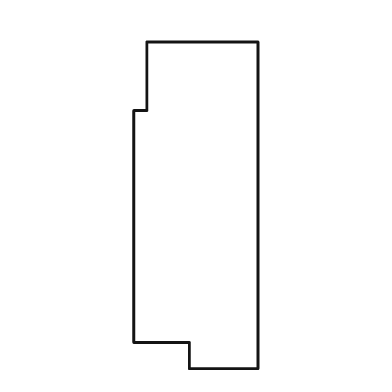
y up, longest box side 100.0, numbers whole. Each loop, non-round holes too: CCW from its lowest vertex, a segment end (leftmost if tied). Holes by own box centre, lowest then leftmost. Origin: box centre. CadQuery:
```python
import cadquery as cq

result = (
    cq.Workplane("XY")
    .moveTo(-2.0, -50.0)
    .lineTo(19.0, -50.0)
    .lineTo(19.0, 50.0)
    .lineTo(-15.0, 50.0)
    .lineTo(-15.0, 29.0)
    .lineTo(-19.0, 29.0)
    .lineTo(-19.0, -42.0)
    .lineTo(-2.0, -42.0)
    .close()
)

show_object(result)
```